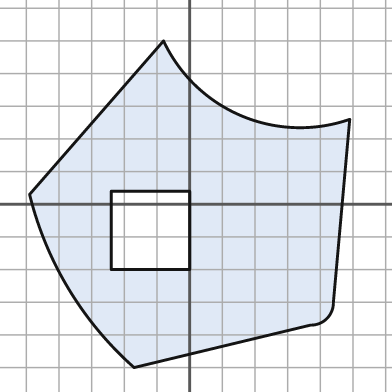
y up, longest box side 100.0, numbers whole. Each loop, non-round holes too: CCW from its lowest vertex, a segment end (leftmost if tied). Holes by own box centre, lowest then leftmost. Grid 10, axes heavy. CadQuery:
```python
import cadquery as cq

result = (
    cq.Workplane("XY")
    .moveTo(-17.0, -50.0)
    .lineTo(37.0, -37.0)
    .threePointArc((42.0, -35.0), (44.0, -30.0))
    .lineTo(49.0, 26.0)
    .threePointArc((16.0, 27.0), (-8.0, 50.0))
    .lineTo(-49.0, 3.0)
    .threePointArc((-37.0, -26.0), (-17.0, -50.0))
    .close()
    .moveTo(-24.0, -20.0)
    .lineTo(0.0, -20.0)
    .lineTo(0.0, 4.0)
    .lineTo(-24.0, 4.0)
    .close()
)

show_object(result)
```